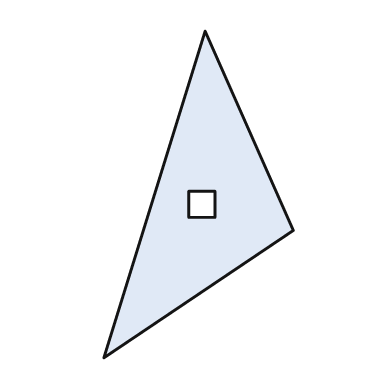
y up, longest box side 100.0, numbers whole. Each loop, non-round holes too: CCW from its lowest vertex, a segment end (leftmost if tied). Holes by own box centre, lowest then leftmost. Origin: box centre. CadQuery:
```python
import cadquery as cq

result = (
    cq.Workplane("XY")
    .moveTo(-29.0, -50.0)
    .lineTo(29.0, -11.0)
    .lineTo(2.0, 50.0)
    .close()
    .moveTo(-3.0, -7.0)
    .lineTo(5.0, -7.0)
    .lineTo(5.0, 1.0)
    .lineTo(-3.0, 1.0)
    .close()
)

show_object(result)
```